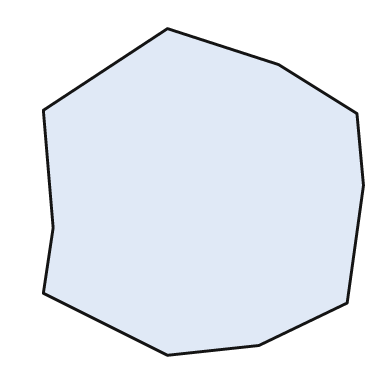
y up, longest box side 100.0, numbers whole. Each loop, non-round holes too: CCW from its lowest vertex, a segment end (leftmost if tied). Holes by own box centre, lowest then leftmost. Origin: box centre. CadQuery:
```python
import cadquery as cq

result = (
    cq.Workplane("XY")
    .moveTo(-11.0, -50.0)
    .lineTo(17.0, -47.0)
    .lineTo(44.0, -34.0)
    .lineTo(49.0, 2.0)
    .lineTo(47.0, 24.0)
    .lineTo(23.0, 39.0)
    .lineTo(-11.0, 50.0)
    .lineTo(-49.0, 25.0)
    .lineTo(-46.0, -11.0)
    .lineTo(-49.0, -31.0)
    .close()
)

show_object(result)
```